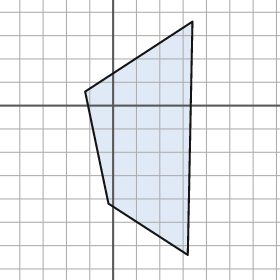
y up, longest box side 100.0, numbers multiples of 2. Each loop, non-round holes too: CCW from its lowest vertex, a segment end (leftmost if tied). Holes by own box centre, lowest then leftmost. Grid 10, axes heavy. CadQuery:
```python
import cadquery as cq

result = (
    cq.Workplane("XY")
    .moveTo(32.0, -64.0)
    .lineTo(34.0, 36.0)
    .lineTo(-12.0, 6.0)
    .lineTo(-2.0, -42.0)
    .close()
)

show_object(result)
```